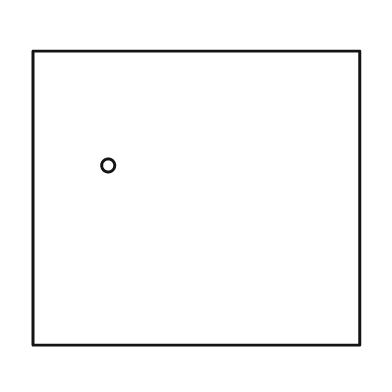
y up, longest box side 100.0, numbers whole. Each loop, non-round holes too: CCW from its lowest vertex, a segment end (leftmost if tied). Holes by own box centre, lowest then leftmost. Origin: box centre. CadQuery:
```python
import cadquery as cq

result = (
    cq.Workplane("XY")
    .moveTo(-50.0, -45.0)
    .lineTo(50.0, -45.0)
    .lineTo(50.0, 45.0)
    .lineTo(-50.0, 45.0)
    .close()
    .moveTo(-27.0, 10.0)
    .circle(2.0)
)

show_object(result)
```